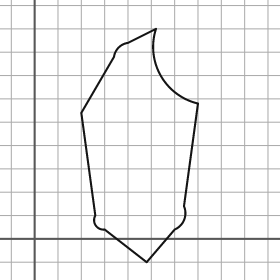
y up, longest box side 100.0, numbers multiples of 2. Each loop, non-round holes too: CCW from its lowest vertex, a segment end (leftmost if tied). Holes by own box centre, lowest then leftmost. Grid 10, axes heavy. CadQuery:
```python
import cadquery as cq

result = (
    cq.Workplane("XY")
    .moveTo(48.0, -10.0)
    .lineTo(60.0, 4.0)
    .threePointArc((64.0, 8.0), (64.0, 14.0))
    .lineTo(70.0, 58.0)
    .threePointArc((54.0, 70.0), (52.0, 90.0))
    .lineTo(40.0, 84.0)
    .threePointArc((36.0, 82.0), (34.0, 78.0))
    .lineTo(20.0, 54.0)
    .lineTo(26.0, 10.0)
    .threePointArc((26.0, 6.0), (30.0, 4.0))
    .close()
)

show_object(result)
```